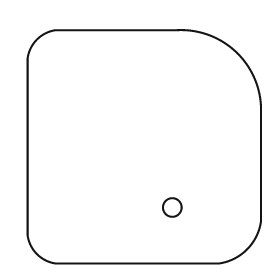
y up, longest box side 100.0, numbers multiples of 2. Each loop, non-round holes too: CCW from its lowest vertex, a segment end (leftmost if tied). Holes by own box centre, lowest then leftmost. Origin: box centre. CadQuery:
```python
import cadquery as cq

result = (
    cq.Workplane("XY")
    .moveTo(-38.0, -50.0)
    .lineTo(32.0, -50.0)
    .threePointArc((44.0, -44.0), (50.0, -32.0))
    .lineTo(50.0, 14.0)
    .threePointArc((40.0, 40.0), (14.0, 50.0))
    .lineTo(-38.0, 50.0)
    .threePointArc((-46.0, 46.0), (-50.0, 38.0))
    .lineTo(-50.0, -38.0)
    .threePointArc((-46.0, -46.0), (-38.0, -50.0))
    .close()
    .moveTo(12.0, -26.0)
    .circle(4.0)
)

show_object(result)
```